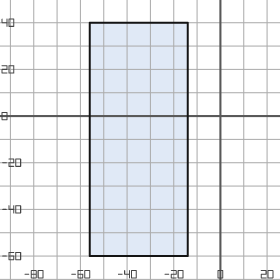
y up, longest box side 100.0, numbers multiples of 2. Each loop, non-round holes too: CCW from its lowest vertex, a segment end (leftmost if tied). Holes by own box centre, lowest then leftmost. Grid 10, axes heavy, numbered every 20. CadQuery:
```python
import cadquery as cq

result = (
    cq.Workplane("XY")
    .moveTo(-56.0, -60.0)
    .lineTo(-14.0, -60.0)
    .lineTo(-14.0, 40.0)
    .lineTo(-56.0, 40.0)
    .close()
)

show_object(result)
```